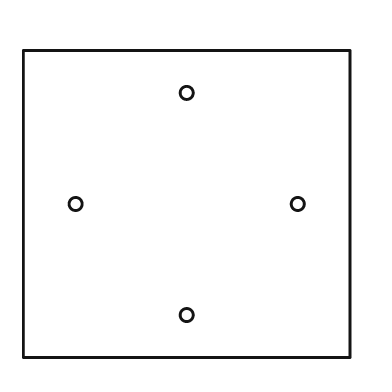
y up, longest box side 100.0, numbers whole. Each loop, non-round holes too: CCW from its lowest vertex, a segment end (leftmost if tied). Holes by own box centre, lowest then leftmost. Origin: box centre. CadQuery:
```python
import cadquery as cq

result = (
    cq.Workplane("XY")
    .moveTo(-50.0, -47.0)
    .lineTo(50.0, -47.0)
    .lineTo(50.0, 47.0)
    .lineTo(-50.0, 47.0)
    .close()
    .moveTo(0.0, -34.0)
    .circle(2.0)
    .moveTo(-34.0, 0.0)
    .circle(2.0)
    .moveTo(34.0, 0.0)
    .circle(2.0)
    .moveTo(0.0, 34.0)
    .circle(2.0)
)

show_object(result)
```